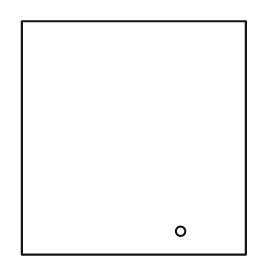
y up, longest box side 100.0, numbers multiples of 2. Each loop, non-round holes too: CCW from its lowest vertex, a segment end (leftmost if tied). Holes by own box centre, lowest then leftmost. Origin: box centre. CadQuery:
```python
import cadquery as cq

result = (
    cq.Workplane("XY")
    .moveTo(-48.0, -50.0)
    .lineTo(48.0, -50.0)
    .lineTo(48.0, 50.0)
    .lineTo(-48.0, 50.0)
    .close()
    .moveTo(20.0, -40.0)
    .circle(2.0)
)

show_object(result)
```